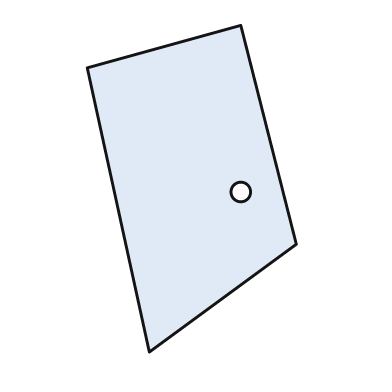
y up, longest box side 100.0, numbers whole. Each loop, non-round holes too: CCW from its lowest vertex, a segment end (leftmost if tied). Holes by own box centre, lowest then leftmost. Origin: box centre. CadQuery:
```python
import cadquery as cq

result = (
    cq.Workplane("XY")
    .moveTo(-13.0, -50.0)
    .lineTo(32.0, -17.0)
    .lineTo(15.0, 50.0)
    .lineTo(-32.0, 37.0)
    .close()
    .moveTo(15.0, -1.0)
    .circle(3.0)
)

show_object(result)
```